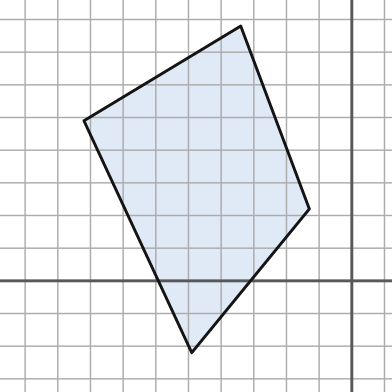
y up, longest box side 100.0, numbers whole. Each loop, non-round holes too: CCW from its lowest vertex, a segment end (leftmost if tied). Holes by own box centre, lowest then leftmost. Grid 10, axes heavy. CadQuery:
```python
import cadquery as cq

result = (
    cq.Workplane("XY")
    .moveTo(-49.0, -22.0)
    .lineTo(-13.0, 22.0)
    .lineTo(-34.0, 78.0)
    .lineTo(-82.0, 49.0)
    .close()
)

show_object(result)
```